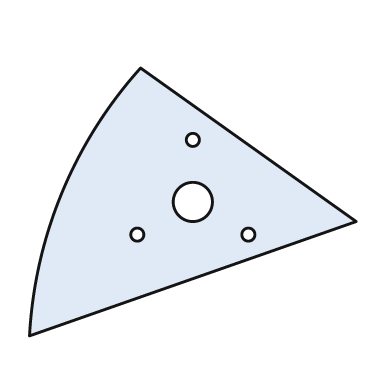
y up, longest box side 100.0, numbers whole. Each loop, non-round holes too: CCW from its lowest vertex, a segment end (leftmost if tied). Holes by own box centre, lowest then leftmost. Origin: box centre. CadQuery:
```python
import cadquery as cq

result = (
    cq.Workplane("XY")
    .moveTo(-50.0, -41.0)
    .lineTo(50.0, -6.0)
    .lineTo(-16.0, 41.0)
    .threePointArc((-40.0, 3.0), (-50.0, -41.0))
    .close()
    .moveTo(-17.0, -10.0)
    .circle(2.0)
    .moveTo(17.0, -10.0)
    .circle(2.0)
    .moveTo(0.0, 0.0)
    .circle(6.0)
    .moveTo(0.0, 19.0)
    .circle(2.0)
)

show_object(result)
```